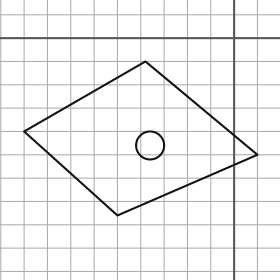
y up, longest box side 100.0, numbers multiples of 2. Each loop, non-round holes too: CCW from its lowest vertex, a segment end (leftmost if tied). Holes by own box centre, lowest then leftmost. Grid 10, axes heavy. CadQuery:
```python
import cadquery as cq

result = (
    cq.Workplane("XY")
    .moveTo(-50.0, -76.0)
    .lineTo(10.0, -50.0)
    .lineTo(-38.0, -10.0)
    .lineTo(-90.0, -40.0)
    .close()
    .moveTo(-36.0, -46.0)
    .circle(6.0)
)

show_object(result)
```